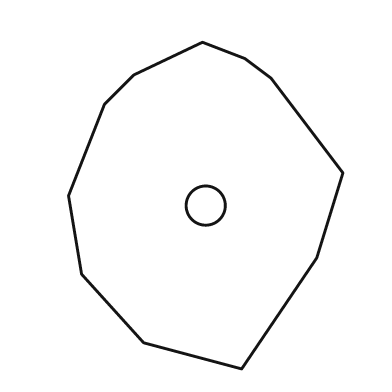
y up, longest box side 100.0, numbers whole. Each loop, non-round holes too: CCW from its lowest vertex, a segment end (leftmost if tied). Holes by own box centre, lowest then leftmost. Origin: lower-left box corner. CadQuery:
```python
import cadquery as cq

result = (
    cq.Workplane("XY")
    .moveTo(53.0, 0.0)
    .lineTo(76.0, 34.0)
    .lineTo(84.0, 60.0)
    .lineTo(62.0, 89.0)
    .lineTo(54.0, 95.0)
    .lineTo(41.0, 100.0)
    .lineTo(20.0, 90.0)
    .lineTo(11.0, 81.0)
    .lineTo(0.0, 53.0)
    .lineTo(4.0, 29.0)
    .lineTo(23.0, 8.0)
    .close()
    .moveTo(42.0, 50.0)
    .circle(6.0)
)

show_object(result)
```